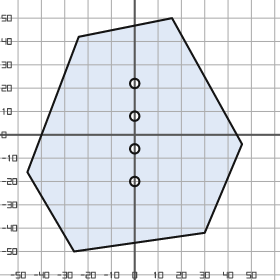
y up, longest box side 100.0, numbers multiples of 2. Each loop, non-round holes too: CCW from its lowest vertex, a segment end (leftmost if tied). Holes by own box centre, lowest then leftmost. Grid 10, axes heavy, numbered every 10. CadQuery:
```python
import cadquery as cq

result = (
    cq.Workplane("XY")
    .moveTo(-26.0, -50.0)
    .lineTo(30.0, -42.0)
    .lineTo(46.0, -4.0)
    .lineTo(16.0, 50.0)
    .lineTo(-24.0, 42.0)
    .lineTo(-46.0, -16.0)
    .close()
    .moveTo(0.0, -20.0)
    .circle(2.0)
    .moveTo(0.0, -6.0)
    .circle(2.0)
    .moveTo(0.0, 8.0)
    .circle(2.0)
    .moveTo(0.0, 22.0)
    .circle(2.0)
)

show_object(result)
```